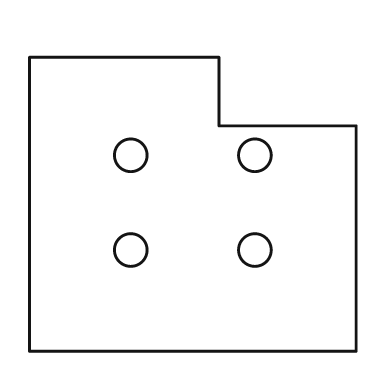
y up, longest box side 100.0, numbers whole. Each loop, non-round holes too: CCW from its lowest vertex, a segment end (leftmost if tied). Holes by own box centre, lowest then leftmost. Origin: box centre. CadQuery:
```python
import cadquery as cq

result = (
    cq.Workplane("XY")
    .moveTo(-50.0, -45.0)
    .lineTo(50.0, -45.0)
    .lineTo(50.0, 24.0)
    .lineTo(8.0, 24.0)
    .lineTo(8.0, 45.0)
    .lineTo(-50.0, 45.0)
    .close()
    .moveTo(-19.0, -14.0)
    .circle(5.0)
    .moveTo(19.0, -14.0)
    .circle(5.0)
    .moveTo(-19.0, 15.0)
    .circle(5.0)
    .moveTo(19.0, 15.0)
    .circle(5.0)
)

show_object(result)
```